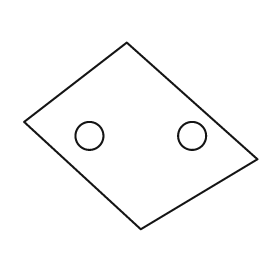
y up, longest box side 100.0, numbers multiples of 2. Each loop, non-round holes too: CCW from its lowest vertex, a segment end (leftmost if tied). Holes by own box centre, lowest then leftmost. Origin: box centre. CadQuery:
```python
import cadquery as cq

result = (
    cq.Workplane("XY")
    .moveTo(0.0, -40.0)
    .lineTo(50.0, -10.0)
    .lineTo(-6.0, 40.0)
    .lineTo(-50.0, 6.0)
    .close()
    .moveTo(-22.0, 0.0)
    .circle(6.0)
    .moveTo(22.0, 0.0)
    .circle(6.0)
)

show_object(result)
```